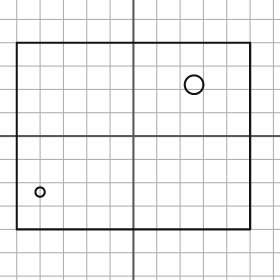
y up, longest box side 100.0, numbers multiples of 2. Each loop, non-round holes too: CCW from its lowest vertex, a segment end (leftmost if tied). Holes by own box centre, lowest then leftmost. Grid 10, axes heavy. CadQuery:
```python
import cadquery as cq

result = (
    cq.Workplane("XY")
    .moveTo(-50.0, -40.0)
    .lineTo(50.0, -40.0)
    .lineTo(50.0, 40.0)
    .lineTo(-50.0, 40.0)
    .close()
    .moveTo(-40.0, -24.0)
    .circle(2.0)
    .moveTo(26.0, 22.0)
    .circle(4.0)
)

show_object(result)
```